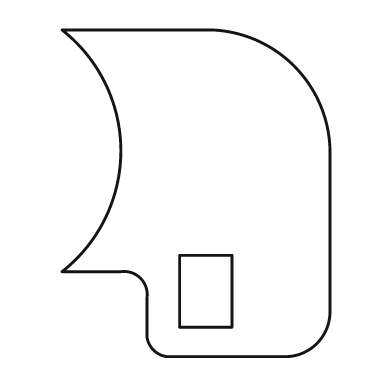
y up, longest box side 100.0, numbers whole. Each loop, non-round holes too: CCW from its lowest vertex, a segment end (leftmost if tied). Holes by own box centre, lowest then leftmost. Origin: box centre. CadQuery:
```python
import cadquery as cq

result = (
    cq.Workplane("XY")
    .moveTo(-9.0, -50.0)
    .lineTo(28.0, -50.0)
    .threePointArc((37.0, -46.0), (41.0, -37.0))
    .lineTo(41.0, 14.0)
    .threePointArc((30.0, 39.0), (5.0, 50.0))
    .lineTo(-41.0, 50.0)
    .threePointArc((-23.0, 13.0), (-41.0, -24.0))
    .lineTo(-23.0, -24.0)
    .threePointArc((-17.0, -26.0), (-15.0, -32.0))
    .lineTo(-15.0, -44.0)
    .threePointArc((-13.0, -48.0), (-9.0, -50.0))
    .close()
    .moveTo(-5.0, -41.0)
    .lineTo(11.0, -41.0)
    .lineTo(11.0, -19.0)
    .lineTo(-5.0, -19.0)
    .close()
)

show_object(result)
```